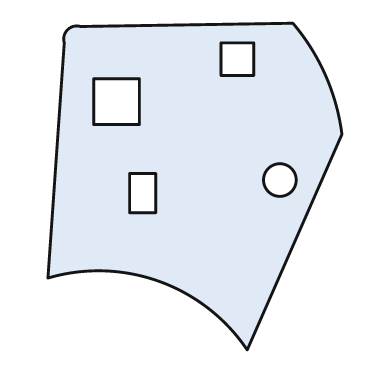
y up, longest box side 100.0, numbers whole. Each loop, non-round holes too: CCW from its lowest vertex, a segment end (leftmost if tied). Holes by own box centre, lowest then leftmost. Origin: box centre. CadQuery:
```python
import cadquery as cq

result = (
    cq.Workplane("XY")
    .moveTo(16.0, -50.0)
    .lineTo(45.0, 16.0)
    .threePointArc((40.0, 34.0), (30.0, 50.0))
    .lineTo(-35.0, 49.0)
    .threePointArc((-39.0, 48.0), (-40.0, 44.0))
    .lineTo(-45.0, -28.0)
    .threePointArc((-11.0, -29.0), (16.0, -50.0))
    .close()
    .moveTo(-20.0, -8.0)
    .lineTo(-12.0, -8.0)
    .lineTo(-12.0, 4.0)
    .lineTo(-20.0, 4.0)
    .close()
    .moveTo(26.0, 2.0)
    .circle(5.0)
    .moveTo(-31.0, 19.0)
    .lineTo(-17.0, 19.0)
    .lineTo(-17.0, 33.0)
    .lineTo(-31.0, 33.0)
    .close()
    .moveTo(8.0, 34.0)
    .lineTo(18.0, 34.0)
    .lineTo(18.0, 44.0)
    .lineTo(8.0, 44.0)
    .close()
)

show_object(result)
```